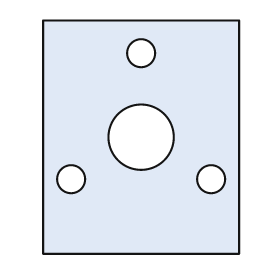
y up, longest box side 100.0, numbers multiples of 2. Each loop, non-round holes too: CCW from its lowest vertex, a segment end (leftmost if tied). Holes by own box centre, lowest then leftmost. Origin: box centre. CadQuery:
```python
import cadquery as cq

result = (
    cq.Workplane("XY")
    .moveTo(-42.0, -50.0)
    .lineTo(42.0, -50.0)
    .lineTo(42.0, 50.0)
    .lineTo(-42.0, 50.0)
    .close()
    .moveTo(-30.0, -18.0)
    .circle(6.0)
    .moveTo(30.0, -18.0)
    .circle(6.0)
    .moveTo(0.0, 0.0)
    .circle(14.0)
    .moveTo(0.0, 36.0)
    .circle(6.0)
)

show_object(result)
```